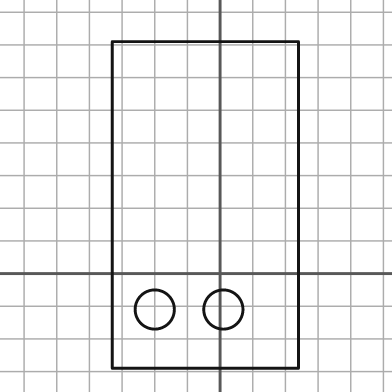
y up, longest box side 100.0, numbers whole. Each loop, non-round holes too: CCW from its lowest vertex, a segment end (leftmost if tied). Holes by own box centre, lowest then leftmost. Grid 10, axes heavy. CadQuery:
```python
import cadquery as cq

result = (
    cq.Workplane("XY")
    .moveTo(-33.0, -29.0)
    .lineTo(24.0, -29.0)
    .lineTo(24.0, 71.0)
    .lineTo(-33.0, 71.0)
    .close()
    .moveTo(-20.0, -11.0)
    .circle(6.0)
    .moveTo(1.0, -11.0)
    .circle(6.0)
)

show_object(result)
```